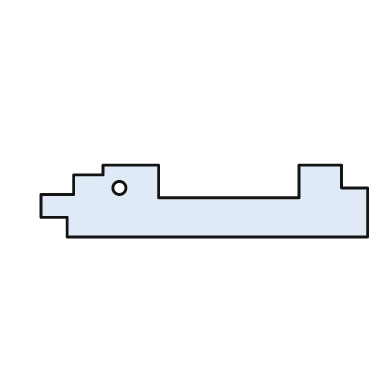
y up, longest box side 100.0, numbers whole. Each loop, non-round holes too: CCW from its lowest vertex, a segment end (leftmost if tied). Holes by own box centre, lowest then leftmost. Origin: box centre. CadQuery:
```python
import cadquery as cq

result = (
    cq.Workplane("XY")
    .moveTo(-42.0, -11.0)
    .lineTo(50.0, -11.0)
    .lineTo(50.0, 4.0)
    .lineTo(42.0, 4.0)
    .lineTo(42.0, 11.0)
    .lineTo(29.0, 11.0)
    .lineTo(29.0, 1.0)
    .lineTo(-14.0, 1.0)
    .lineTo(-14.0, 11.0)
    .lineTo(-31.0, 11.0)
    .lineTo(-31.0, 8.0)
    .lineTo(-40.0, 8.0)
    .lineTo(-40.0, 2.0)
    .lineTo(-50.0, 2.0)
    .lineTo(-50.0, -5.0)
    .lineTo(-42.0, -5.0)
    .close()
    .moveTo(-26.0, 4.0)
    .circle(2.0)
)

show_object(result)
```